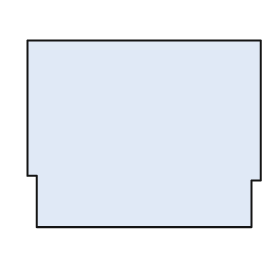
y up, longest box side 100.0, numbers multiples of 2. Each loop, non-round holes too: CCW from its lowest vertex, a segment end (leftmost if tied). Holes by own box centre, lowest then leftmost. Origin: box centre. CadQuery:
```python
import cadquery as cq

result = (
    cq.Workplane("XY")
    .moveTo(-46.0, -40.0)
    .lineTo(46.0, -40.0)
    .lineTo(46.0, -20.0)
    .lineTo(50.0, -20.0)
    .lineTo(50.0, 40.0)
    .lineTo(-50.0, 40.0)
    .lineTo(-50.0, -18.0)
    .lineTo(-46.0, -18.0)
    .close()
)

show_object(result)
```